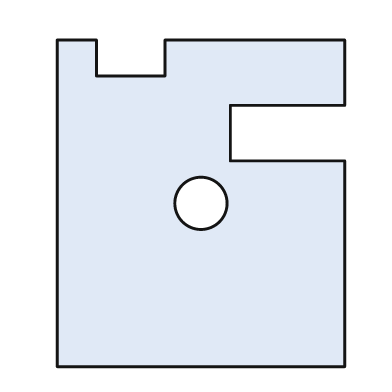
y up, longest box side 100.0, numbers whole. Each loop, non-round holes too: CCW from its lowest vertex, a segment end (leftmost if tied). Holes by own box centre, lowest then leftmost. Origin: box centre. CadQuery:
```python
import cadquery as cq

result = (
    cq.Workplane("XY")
    .moveTo(-44.0, -50.0)
    .lineTo(44.0, -50.0)
    .lineTo(44.0, 13.0)
    .lineTo(9.0, 13.0)
    .lineTo(9.0, 30.0)
    .lineTo(44.0, 30.0)
    .lineTo(44.0, 50.0)
    .lineTo(-11.0, 50.0)
    .lineTo(-11.0, 39.0)
    .lineTo(-32.0, 39.0)
    .lineTo(-32.0, 50.0)
    .lineTo(-44.0, 50.0)
    .close()
    .moveTo(0.0, 0.0)
    .circle(8.0)
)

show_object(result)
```